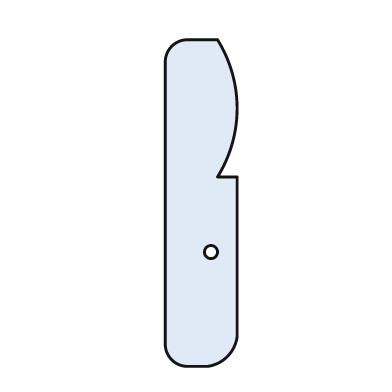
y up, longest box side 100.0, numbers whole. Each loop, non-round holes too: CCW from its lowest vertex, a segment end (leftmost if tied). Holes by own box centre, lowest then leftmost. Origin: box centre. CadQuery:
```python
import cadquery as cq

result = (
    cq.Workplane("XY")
    .moveTo(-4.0, -50.0)
    .lineTo(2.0, -50.0)
    .threePointArc((8.0, -47.0), (11.0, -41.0))
    .lineTo(11.0, 8.0)
    .lineTo(5.0, 8.0)
    .threePointArc((11.0, 29.0), (5.0, 50.0))
    .lineTo(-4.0, 50.0)
    .threePointArc((-9.0, 48.0), (-11.0, 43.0))
    .lineTo(-11.0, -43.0)
    .threePointArc((-9.0, -48.0), (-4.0, -50.0))
    .close()
    .moveTo(3.0, -15.0)
    .circle(2.0)
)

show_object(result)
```